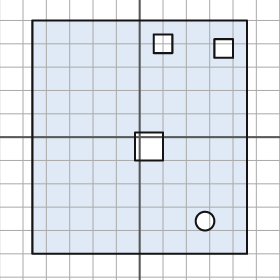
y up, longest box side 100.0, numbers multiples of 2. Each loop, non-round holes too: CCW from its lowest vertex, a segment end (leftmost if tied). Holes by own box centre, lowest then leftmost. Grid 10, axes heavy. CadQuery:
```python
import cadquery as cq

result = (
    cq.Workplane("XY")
    .moveTo(-46.0, -50.0)
    .lineTo(46.0, -50.0)
    .lineTo(46.0, 50.0)
    .lineTo(-46.0, 50.0)
    .close()
    .moveTo(28.0, -36.0)
    .circle(4.0)
    .moveTo(-2.0, -10.0)
    .lineTo(10.0, -10.0)
    .lineTo(10.0, 2.0)
    .lineTo(-2.0, 2.0)
    .close()
    .moveTo(32.0, 34.0)
    .lineTo(40.0, 34.0)
    .lineTo(40.0, 42.0)
    .lineTo(32.0, 42.0)
    .close()
    .moveTo(6.0, 36.0)
    .lineTo(14.0, 36.0)
    .lineTo(14.0, 44.0)
    .lineTo(6.0, 44.0)
    .close()
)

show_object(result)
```